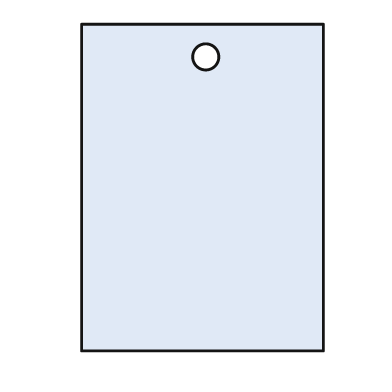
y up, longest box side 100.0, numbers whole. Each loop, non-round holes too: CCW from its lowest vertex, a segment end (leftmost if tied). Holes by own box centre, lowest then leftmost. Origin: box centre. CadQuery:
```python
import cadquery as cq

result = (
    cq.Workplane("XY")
    .moveTo(-37.0, -50.0)
    .lineTo(37.0, -50.0)
    .lineTo(37.0, 50.0)
    .lineTo(-37.0, 50.0)
    .close()
    .moveTo(1.0, 40.0)
    .circle(4.0)
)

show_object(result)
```